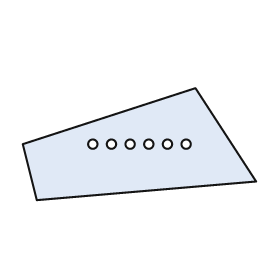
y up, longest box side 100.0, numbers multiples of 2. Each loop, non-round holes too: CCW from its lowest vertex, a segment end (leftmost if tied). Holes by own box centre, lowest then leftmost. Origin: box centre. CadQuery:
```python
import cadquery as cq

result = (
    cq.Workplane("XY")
    .moveTo(-44.0, -24.0)
    .lineTo(50.0, -16.0)
    .lineTo(24.0, 24.0)
    .lineTo(-50.0, 0.0)
    .close()
    .moveTo(-20.0, 0.0)
    .circle(2.0)
    .moveTo(-12.0, 0.0)
    .circle(2.0)
    .moveTo(-4.0, 0.0)
    .circle(2.0)
    .moveTo(4.0, 0.0)
    .circle(2.0)
    .moveTo(12.0, 0.0)
    .circle(2.0)
    .moveTo(20.0, 0.0)
    .circle(2.0)
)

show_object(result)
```